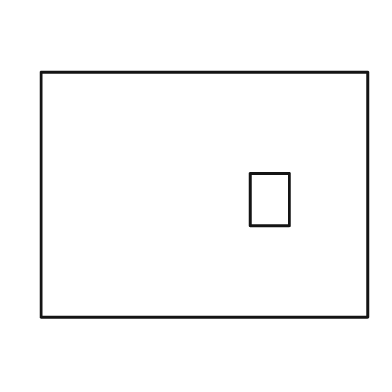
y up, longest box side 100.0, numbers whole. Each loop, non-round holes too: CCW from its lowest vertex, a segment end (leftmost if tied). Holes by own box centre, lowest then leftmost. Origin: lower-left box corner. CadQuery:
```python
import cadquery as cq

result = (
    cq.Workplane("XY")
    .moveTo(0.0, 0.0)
    .lineTo(100.0, 0.0)
    .lineTo(100.0, 75.0)
    .lineTo(0.0, 75.0)
    .close()
    .moveTo(64.0, 28.0)
    .lineTo(76.0, 28.0)
    .lineTo(76.0, 44.0)
    .lineTo(64.0, 44.0)
    .close()
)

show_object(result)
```